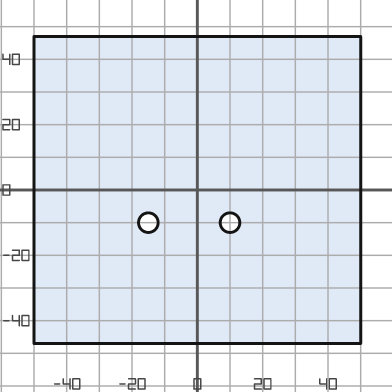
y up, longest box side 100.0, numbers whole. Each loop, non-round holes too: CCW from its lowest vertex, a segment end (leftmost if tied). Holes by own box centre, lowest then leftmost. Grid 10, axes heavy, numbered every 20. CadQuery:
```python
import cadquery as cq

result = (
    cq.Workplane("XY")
    .moveTo(-50.0, -47.0)
    .lineTo(50.0, -47.0)
    .lineTo(50.0, 47.0)
    .lineTo(-50.0, 47.0)
    .close()
    .moveTo(-15.0, -10.0)
    .circle(3.0)
    .moveTo(10.0, -10.0)
    .circle(3.0)
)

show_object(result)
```